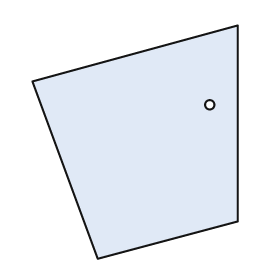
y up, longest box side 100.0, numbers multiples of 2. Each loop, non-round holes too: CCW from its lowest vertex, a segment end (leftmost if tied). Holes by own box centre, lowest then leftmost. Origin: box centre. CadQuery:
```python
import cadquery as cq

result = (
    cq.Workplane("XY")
    .moveTo(-16.0, -50.0)
    .lineTo(44.0, -34.0)
    .lineTo(44.0, 50.0)
    .lineTo(-44.0, 26.0)
    .close()
    .moveTo(32.0, 16.0)
    .circle(2.0)
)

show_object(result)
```